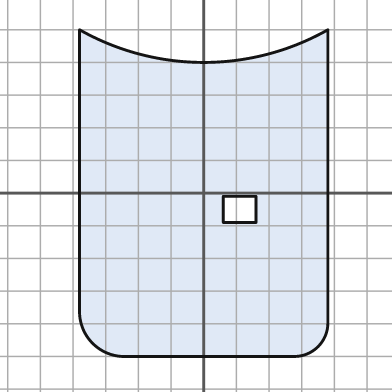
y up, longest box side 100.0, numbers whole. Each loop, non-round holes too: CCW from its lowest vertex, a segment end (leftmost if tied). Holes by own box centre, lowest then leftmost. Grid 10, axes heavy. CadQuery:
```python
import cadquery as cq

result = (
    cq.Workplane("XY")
    .moveTo(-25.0, -50.0)
    .lineTo(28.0, -50.0)
    .threePointArc((35.0, -47.0), (38.0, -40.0))
    .lineTo(38.0, 50.0)
    .threePointArc((0.0, 40.0), (-38.0, 50.0))
    .lineTo(-38.0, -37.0)
    .threePointArc((-34.0, -46.0), (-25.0, -50.0))
    .close()
    .moveTo(6.0, -9.0)
    .lineTo(16.0, -9.0)
    .lineTo(16.0, -1.0)
    .lineTo(6.0, -1.0)
    .close()
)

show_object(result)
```